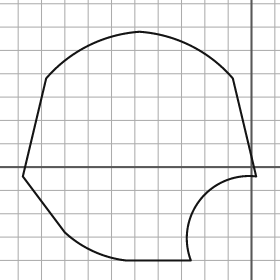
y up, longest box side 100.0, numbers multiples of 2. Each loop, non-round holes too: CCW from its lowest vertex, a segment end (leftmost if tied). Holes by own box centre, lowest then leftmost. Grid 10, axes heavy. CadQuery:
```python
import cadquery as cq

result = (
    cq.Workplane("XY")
    .moveTo(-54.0, -40.0)
    .lineTo(-26.0, -40.0)
    .threePointArc((-22.0, -14.0), (2.0, -4.0))
    .lineTo(-8.0, 38.0)
    .threePointArc((-26.0, 52.0), (-48.0, 58.0))
    .threePointArc((-70.0, 52.0), (-88.0, 38.0))
    .lineTo(-98.0, -4.0)
    .lineTo(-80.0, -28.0)
    .threePointArc((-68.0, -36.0), (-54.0, -40.0))
    .close()
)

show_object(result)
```